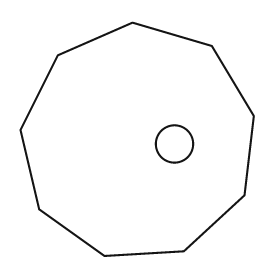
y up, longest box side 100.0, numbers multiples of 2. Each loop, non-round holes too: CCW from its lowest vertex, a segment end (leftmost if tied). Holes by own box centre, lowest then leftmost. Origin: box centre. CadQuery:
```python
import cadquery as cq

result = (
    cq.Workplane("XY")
    .moveTo(-14.0, -50.0)
    .lineTo(20.0, -48.0)
    .lineTo(46.0, -24.0)
    .lineTo(50.0, 10.0)
    .lineTo(32.0, 40.0)
    .lineTo(-2.0, 50.0)
    .lineTo(-34.0, 36.0)
    .lineTo(-50.0, 4.0)
    .lineTo(-42.0, -30.0)
    .close()
    .moveTo(16.0, -2.0)
    .circle(8.0)
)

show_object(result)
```